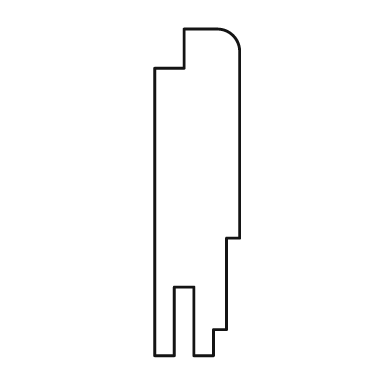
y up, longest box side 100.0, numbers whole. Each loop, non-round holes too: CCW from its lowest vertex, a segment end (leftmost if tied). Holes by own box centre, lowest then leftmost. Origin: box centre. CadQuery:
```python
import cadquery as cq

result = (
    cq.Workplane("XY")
    .moveTo(-13.0, -50.0)
    .lineTo(-7.0, -50.0)
    .lineTo(-7.0, -29.0)
    .lineTo(-1.0, -29.0)
    .lineTo(-1.0, -50.0)
    .lineTo(5.0, -50.0)
    .lineTo(5.0, -42.0)
    .lineTo(9.0, -42.0)
    .lineTo(9.0, -14.0)
    .lineTo(13.0, -14.0)
    .lineTo(13.0, 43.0)
    .threePointArc((11.0, 48.0), (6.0, 50.0))
    .lineTo(-4.0, 50.0)
    .lineTo(-4.0, 38.0)
    .lineTo(-13.0, 38.0)
    .close()
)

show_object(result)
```